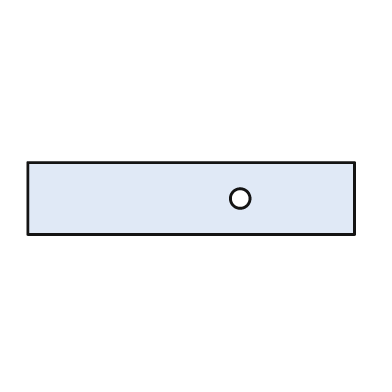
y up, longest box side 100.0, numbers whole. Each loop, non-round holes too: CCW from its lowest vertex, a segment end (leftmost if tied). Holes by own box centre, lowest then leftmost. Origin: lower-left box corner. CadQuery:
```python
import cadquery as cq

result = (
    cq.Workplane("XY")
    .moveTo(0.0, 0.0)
    .lineTo(100.0, 0.0)
    .lineTo(100.0, 22.0)
    .lineTo(0.0, 22.0)
    .close()
    .moveTo(65.0, 11.0)
    .circle(3.0)
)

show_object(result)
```